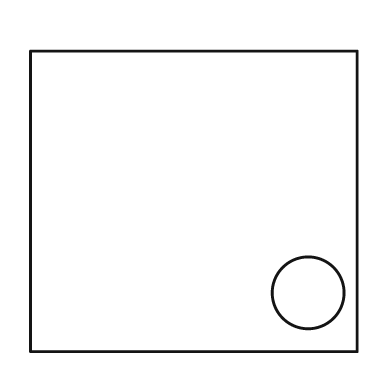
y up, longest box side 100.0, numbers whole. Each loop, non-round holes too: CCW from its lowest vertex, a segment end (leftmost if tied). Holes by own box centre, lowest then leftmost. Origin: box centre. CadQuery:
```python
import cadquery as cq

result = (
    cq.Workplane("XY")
    .moveTo(-50.0, -46.0)
    .lineTo(50.0, -46.0)
    .lineTo(50.0, 46.0)
    .lineTo(-50.0, 46.0)
    .close()
    .moveTo(35.0, -28.0)
    .circle(11.0)
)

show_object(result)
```